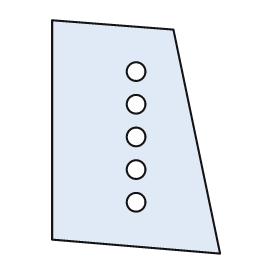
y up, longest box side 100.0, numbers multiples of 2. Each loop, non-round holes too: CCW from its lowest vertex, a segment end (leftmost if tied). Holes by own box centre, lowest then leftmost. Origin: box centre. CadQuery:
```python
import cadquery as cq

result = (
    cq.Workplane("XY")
    .moveTo(36.0, -50.0)
    .lineTo(16.0, 46.0)
    .lineTo(-36.0, 50.0)
    .lineTo(-36.0, -44.0)
    .close()
    .moveTo(0.0, -28.0)
    .circle(4.0)
    .moveTo(0.0, -14.0)
    .circle(4.0)
    .moveTo(0.0, 0.0)
    .circle(4.0)
    .moveTo(0.0, 14.0)
    .circle(4.0)
    .moveTo(0.0, 28.0)
    .circle(4.0)
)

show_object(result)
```